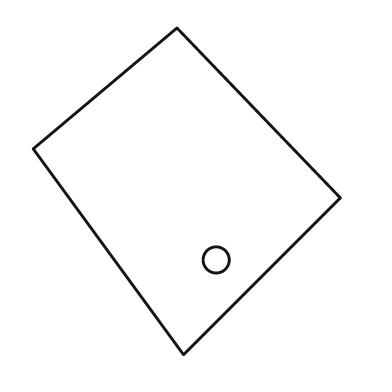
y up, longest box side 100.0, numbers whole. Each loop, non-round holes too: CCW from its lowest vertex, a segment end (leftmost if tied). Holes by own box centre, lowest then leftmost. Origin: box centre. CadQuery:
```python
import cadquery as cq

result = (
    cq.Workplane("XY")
    .moveTo(-1.0, -50.0)
    .lineTo(47.0, -2.0)
    .lineTo(-3.0, 50.0)
    .lineTo(-47.0, 13.0)
    .close()
    .moveTo(9.0, -21.0)
    .circle(4.0)
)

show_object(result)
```